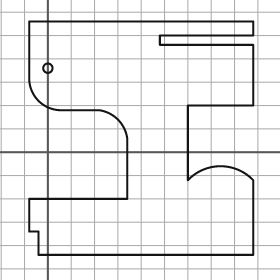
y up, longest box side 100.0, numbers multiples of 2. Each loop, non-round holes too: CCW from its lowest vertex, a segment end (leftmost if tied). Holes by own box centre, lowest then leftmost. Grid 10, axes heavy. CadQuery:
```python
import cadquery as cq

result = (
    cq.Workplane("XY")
    .moveTo(-4.0, -44.0)
    .lineTo(88.0, -44.0)
    .lineTo(88.0, -12.0)
    .threePointArc((74.0, -6.0), (60.0, -12.0))
    .lineTo(60.0, 20.0)
    .lineTo(88.0, 20.0)
    .lineTo(88.0, 46.0)
    .lineTo(48.0, 46.0)
    .lineTo(48.0, 50.0)
    .lineTo(88.0, 50.0)
    .lineTo(88.0, 56.0)
    .lineTo(-8.0, 56.0)
    .lineTo(-8.0, 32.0)
    .threePointArc((-4.0, 22.0), (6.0, 18.0))
    .lineTo(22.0, 18.0)
    .threePointArc((30.0, 14.0), (34.0, 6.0))
    .lineTo(34.0, -20.0)
    .lineTo(-8.0, -20.0)
    .lineTo(-8.0, -34.0)
    .lineTo(-4.0, -34.0)
    .close()
    .moveTo(0.0, 36.0)
    .circle(2.0)
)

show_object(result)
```